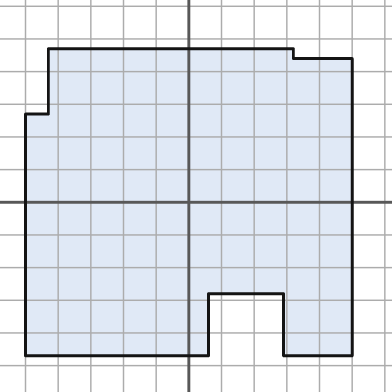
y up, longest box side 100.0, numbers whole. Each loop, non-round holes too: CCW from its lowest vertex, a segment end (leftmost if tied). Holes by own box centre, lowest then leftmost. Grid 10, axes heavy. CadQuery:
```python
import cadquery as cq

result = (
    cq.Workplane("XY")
    .moveTo(-50.0, -47.0)
    .lineTo(6.0, -47.0)
    .lineTo(6.0, -28.0)
    .lineTo(29.0, -28.0)
    .lineTo(29.0, -47.0)
    .lineTo(50.0, -47.0)
    .lineTo(50.0, 44.0)
    .lineTo(32.0, 44.0)
    .lineTo(32.0, 47.0)
    .lineTo(-43.0, 47.0)
    .lineTo(-43.0, 27.0)
    .lineTo(-50.0, 27.0)
    .close()
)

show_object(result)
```